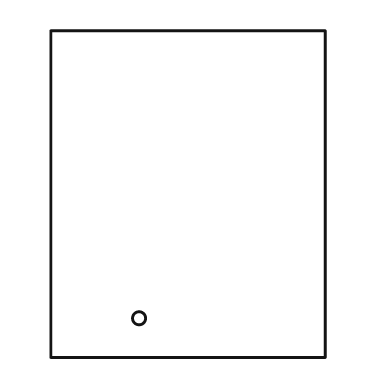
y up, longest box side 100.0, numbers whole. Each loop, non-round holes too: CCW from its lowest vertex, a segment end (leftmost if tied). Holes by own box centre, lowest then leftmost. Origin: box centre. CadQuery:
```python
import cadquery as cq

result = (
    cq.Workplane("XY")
    .moveTo(-42.0, -50.0)
    .lineTo(42.0, -50.0)
    .lineTo(42.0, 50.0)
    .lineTo(-42.0, 50.0)
    .close()
    .moveTo(-15.0, -38.0)
    .circle(2.0)
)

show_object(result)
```